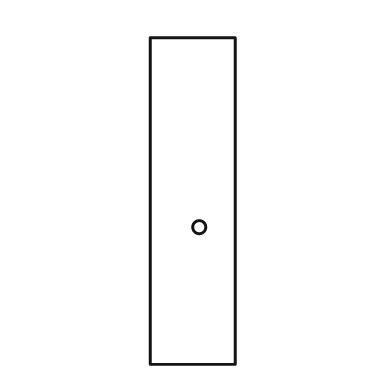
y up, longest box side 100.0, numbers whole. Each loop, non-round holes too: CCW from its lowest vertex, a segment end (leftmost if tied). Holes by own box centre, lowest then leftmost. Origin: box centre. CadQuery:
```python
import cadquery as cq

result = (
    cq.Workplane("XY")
    .moveTo(-13.0, -50.0)
    .lineTo(13.0, -50.0)
    .lineTo(13.0, 50.0)
    .lineTo(-13.0, 50.0)
    .close()
    .moveTo(2.0, -8.0)
    .circle(2.0)
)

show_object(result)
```